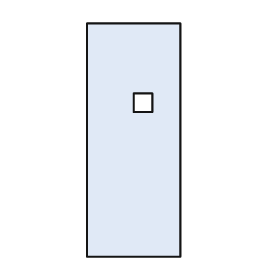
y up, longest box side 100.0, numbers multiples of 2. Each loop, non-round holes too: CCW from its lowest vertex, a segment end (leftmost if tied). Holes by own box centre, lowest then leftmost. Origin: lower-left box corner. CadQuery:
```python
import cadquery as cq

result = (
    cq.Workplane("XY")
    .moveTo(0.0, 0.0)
    .lineTo(40.0, 0.0)
    .lineTo(40.0, 100.0)
    .lineTo(0.0, 100.0)
    .close()
    .moveTo(20.0, 62.0)
    .lineTo(28.0, 62.0)
    .lineTo(28.0, 70.0)
    .lineTo(20.0, 70.0)
    .close()
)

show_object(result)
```